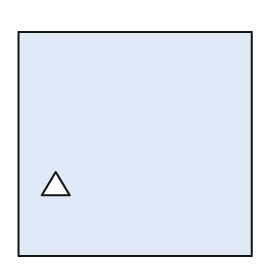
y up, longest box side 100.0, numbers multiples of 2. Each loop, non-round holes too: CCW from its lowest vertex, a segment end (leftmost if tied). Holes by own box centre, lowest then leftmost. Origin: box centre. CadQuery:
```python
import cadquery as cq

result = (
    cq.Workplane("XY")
    .moveTo(-50.0, -48.0)
    .lineTo(50.0, -48.0)
    .lineTo(50.0, 48.0)
    .lineTo(-50.0, 48.0)
    .close()
    .moveTo(-40.0, -22.0)
    .lineTo(-28.0, -22.0)
    .lineTo(-34.0, -12.0)
    .close()
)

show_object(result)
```